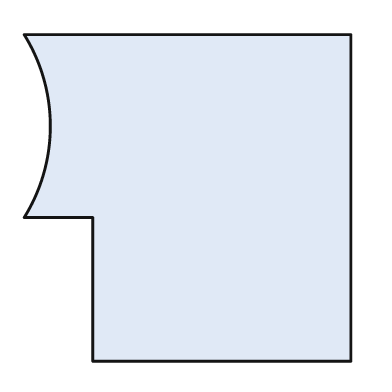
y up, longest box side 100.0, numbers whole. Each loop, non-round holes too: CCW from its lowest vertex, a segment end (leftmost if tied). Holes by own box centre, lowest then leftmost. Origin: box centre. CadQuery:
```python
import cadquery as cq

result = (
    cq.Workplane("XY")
    .moveTo(-29.0, -50.0)
    .lineTo(50.0, -50.0)
    .lineTo(50.0, 50.0)
    .lineTo(-50.0, 50.0)
    .threePointArc((-42.0, 22.0), (-50.0, -6.0))
    .lineTo(-29.0, -6.0)
    .close()
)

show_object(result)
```